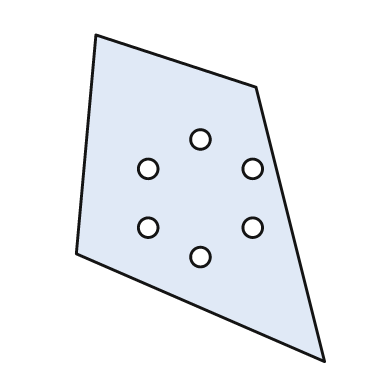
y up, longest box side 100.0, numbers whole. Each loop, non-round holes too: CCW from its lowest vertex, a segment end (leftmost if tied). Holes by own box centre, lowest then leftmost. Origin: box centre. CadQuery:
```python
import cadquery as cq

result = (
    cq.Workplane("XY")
    .moveTo(38.0, -50.0)
    .lineTo(17.0, 34.0)
    .lineTo(-32.0, 50.0)
    .lineTo(-38.0, -17.0)
    .close()
    .moveTo(0.0, -18.0)
    .circle(3.0)
    .moveTo(-16.0, -9.0)
    .circle(3.0)
    .moveTo(16.0, -9.0)
    .circle(3.0)
    .moveTo(-16.0, 9.0)
    .circle(3.0)
    .moveTo(16.0, 9.0)
    .circle(3.0)
    .moveTo(0.0, 18.0)
    .circle(3.0)
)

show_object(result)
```